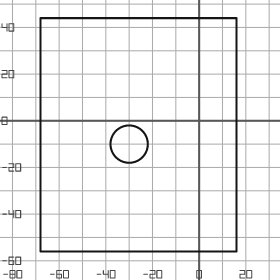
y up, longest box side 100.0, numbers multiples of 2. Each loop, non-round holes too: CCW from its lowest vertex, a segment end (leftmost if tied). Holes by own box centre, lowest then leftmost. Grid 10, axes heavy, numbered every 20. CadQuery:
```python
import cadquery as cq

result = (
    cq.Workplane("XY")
    .moveTo(-68.0, -56.0)
    .lineTo(16.0, -56.0)
    .lineTo(16.0, 44.0)
    .lineTo(-68.0, 44.0)
    .close()
    .moveTo(-30.0, -10.0)
    .circle(8.0)
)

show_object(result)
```